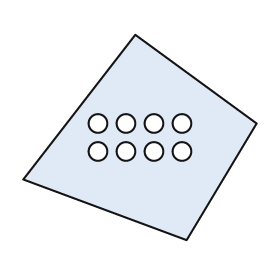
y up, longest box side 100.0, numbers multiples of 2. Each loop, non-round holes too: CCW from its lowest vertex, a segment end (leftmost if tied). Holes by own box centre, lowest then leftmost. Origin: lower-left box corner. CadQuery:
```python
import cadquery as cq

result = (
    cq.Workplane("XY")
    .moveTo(70.0, 0.0)
    .lineTo(100.0, 50.0)
    .lineTo(48.0, 88.0)
    .lineTo(0.0, 26.0)
    .close()
    .moveTo(32.0, 38.0)
    .circle(4.0)
    .moveTo(44.0, 38.0)
    .circle(4.0)
    .moveTo(56.0, 38.0)
    .circle(4.0)
    .moveTo(68.0, 38.0)
    .circle(4.0)
    .moveTo(32.0, 50.0)
    .circle(4.0)
    .moveTo(44.0, 50.0)
    .circle(4.0)
    .moveTo(56.0, 50.0)
    .circle(4.0)
    .moveTo(68.0, 50.0)
    .circle(4.0)
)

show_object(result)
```